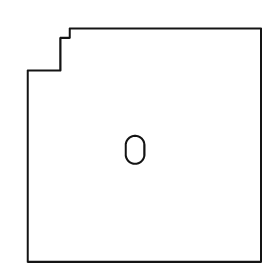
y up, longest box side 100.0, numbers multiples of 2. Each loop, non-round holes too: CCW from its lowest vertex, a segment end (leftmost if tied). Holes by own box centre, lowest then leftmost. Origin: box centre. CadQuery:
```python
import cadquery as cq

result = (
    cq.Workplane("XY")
    .moveTo(-50.0, -50.0)
    .lineTo(50.0, -50.0)
    .lineTo(50.0, 50.0)
    .lineTo(-32.0, 50.0)
    .lineTo(-32.0, 46.0)
    .lineTo(-36.0, 46.0)
    .lineTo(-36.0, 32.0)
    .lineTo(-50.0, 32.0)
    .close()
    .moveTo(-8.0, -4.0)
    .threePointArc((-4.0, -8.0), (0.0, -4.0))
    .lineTo(0.0, 0.0)
    .threePointArc((-4.0, 4.0), (-8.0, 0.0))
    .close()
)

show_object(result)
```